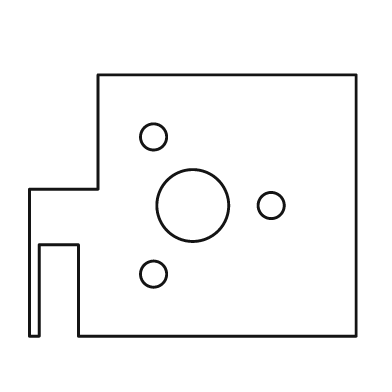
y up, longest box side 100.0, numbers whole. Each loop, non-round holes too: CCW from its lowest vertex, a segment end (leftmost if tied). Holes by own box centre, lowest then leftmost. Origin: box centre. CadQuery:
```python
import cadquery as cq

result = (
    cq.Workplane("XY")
    .moveTo(-50.0, -40.0)
    .lineTo(-47.0, -40.0)
    .lineTo(-47.0, -12.0)
    .lineTo(-35.0, -12.0)
    .lineTo(-35.0, -40.0)
    .lineTo(50.0, -40.0)
    .lineTo(50.0, 40.0)
    .lineTo(-29.0, 40.0)
    .lineTo(-29.0, 5.0)
    .lineTo(-50.0, 5.0)
    .close()
    .moveTo(-12.0, -21.0)
    .circle(4.0)
    .moveTo(0.0, 0.0)
    .circle(11.0)
    .moveTo(24.0, 0.0)
    .circle(4.0)
    .moveTo(-12.0, 21.0)
    .circle(4.0)
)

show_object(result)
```